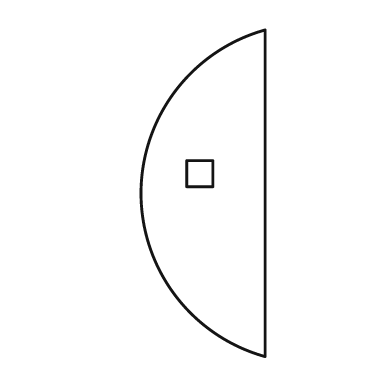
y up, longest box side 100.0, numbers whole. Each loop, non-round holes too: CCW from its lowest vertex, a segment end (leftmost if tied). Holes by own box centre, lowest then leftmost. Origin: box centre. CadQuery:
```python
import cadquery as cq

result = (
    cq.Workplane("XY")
    .moveTo(19.0, -50.0)
    .lineTo(19.0, 50.0)
    .threePointArc((-19.0, 0.0), (19.0, -50.0))
    .close()
    .moveTo(-5.0, 2.0)
    .lineTo(3.0, 2.0)
    .lineTo(3.0, 10.0)
    .lineTo(-5.0, 10.0)
    .close()
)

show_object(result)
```